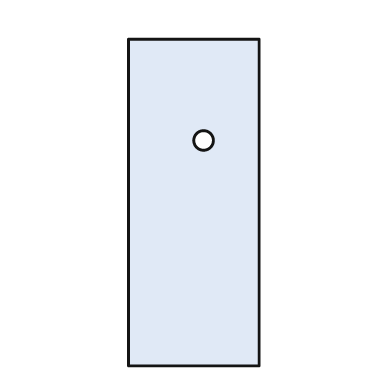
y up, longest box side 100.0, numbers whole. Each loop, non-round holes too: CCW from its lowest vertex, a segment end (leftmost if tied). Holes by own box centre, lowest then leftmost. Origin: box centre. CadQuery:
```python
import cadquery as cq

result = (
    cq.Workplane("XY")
    .moveTo(-20.0, -50.0)
    .lineTo(20.0, -50.0)
    .lineTo(20.0, 50.0)
    .lineTo(-20.0, 50.0)
    .close()
    .moveTo(3.0, 19.0)
    .circle(3.0)
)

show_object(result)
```